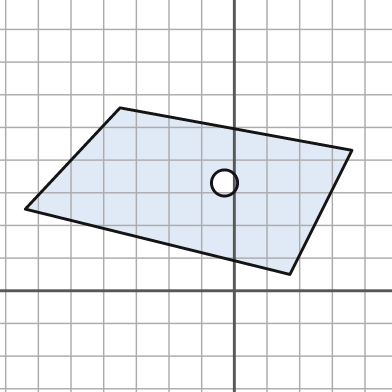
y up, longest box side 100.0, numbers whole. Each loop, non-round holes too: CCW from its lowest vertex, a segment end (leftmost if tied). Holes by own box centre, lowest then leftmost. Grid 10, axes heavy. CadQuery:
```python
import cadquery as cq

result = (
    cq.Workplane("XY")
    .moveTo(17.0, 5.0)
    .lineTo(36.0, 43.0)
    .lineTo(-35.0, 56.0)
    .lineTo(-64.0, 25.0)
    .close()
    .moveTo(-3.0, 33.0)
    .circle(4.0)
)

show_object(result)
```